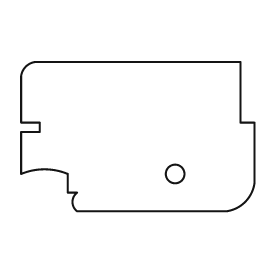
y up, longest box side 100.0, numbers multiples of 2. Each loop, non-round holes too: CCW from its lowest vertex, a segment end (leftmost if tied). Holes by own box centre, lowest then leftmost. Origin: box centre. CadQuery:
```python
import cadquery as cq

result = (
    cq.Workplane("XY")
    .moveTo(-26.0, -32.0)
    .lineTo(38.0, -32.0)
    .threePointArc((46.0, -28.0), (50.0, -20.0))
    .lineTo(50.0, 6.0)
    .lineTo(44.0, 6.0)
    .lineTo(44.0, 32.0)
    .lineTo(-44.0, 32.0)
    .threePointArc((-48.0, 30.0), (-50.0, 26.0))
    .lineTo(-50.0, 6.0)
    .lineTo(-42.0, 6.0)
    .lineTo(-42.0, 2.0)
    .lineTo(-50.0, 2.0)
    .lineTo(-50.0, -16.0)
    .threePointArc((-40.0, -14.0), (-30.0, -16.0))
    .lineTo(-30.0, -24.0)
    .lineTo(-26.0, -24.0)
    .threePointArc((-28.0, -28.0), (-26.0, -32.0))
    .close()
    .moveTo(16.0, -16.0)
    .circle(4.0)
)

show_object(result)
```